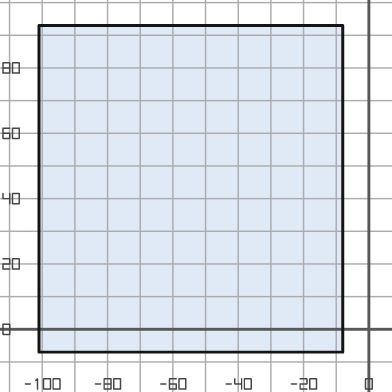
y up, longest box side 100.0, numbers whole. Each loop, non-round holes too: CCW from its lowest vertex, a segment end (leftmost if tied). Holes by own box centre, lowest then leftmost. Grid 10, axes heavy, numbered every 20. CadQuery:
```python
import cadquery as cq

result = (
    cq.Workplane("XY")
    .moveTo(-101.0, -7.0)
    .lineTo(-8.0, -7.0)
    .lineTo(-8.0, 93.0)
    .lineTo(-101.0, 93.0)
    .close()
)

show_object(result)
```